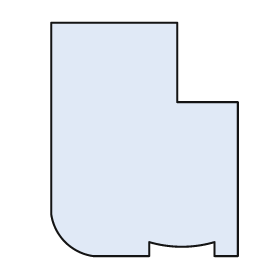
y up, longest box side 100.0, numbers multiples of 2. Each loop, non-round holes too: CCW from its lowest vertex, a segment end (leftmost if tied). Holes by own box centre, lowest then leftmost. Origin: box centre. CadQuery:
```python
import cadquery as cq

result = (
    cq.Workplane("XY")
    .moveTo(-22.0, -50.0)
    .lineTo(2.0, -50.0)
    .lineTo(2.0, -44.0)
    .threePointArc((16.0, -46.0), (30.0, -44.0))
    .lineTo(30.0, -50.0)
    .lineTo(40.0, -50.0)
    .lineTo(40.0, 16.0)
    .lineTo(14.0, 16.0)
    .lineTo(14.0, 50.0)
    .lineTo(-40.0, 50.0)
    .lineTo(-40.0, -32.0)
    .threePointArc((-34.0, -44.0), (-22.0, -50.0))
    .close()
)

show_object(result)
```